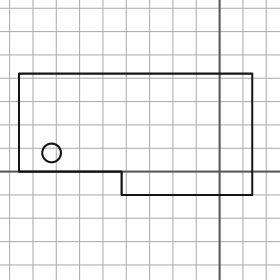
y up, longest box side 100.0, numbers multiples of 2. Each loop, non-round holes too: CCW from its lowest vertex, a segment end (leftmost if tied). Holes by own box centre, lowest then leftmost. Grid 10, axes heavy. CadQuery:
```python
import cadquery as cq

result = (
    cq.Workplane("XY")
    .moveTo(-42.0, -10.0)
    .lineTo(14.0, -10.0)
    .lineTo(14.0, 42.0)
    .lineTo(-86.0, 42.0)
    .lineTo(-86.0, 0.0)
    .lineTo(-42.0, 0.0)
    .close()
    .moveTo(-72.0, 8.0)
    .circle(4.0)
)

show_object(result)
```